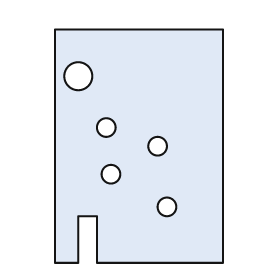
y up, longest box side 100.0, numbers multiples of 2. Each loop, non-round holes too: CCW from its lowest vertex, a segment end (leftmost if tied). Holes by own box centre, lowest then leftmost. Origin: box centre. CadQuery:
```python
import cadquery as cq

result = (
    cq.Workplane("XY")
    .moveTo(-36.0, -50.0)
    .lineTo(-26.0, -50.0)
    .lineTo(-26.0, -30.0)
    .lineTo(-18.0, -30.0)
    .lineTo(-18.0, -50.0)
    .lineTo(36.0, -50.0)
    .lineTo(36.0, 50.0)
    .lineTo(-36.0, 50.0)
    .close()
    .moveTo(12.0, -26.0)
    .circle(4.0)
    .moveTo(-12.0, -12.0)
    .circle(4.0)
    .moveTo(8.0, 0.0)
    .circle(4.0)
    .moveTo(-14.0, 8.0)
    .circle(4.0)
    .moveTo(-26.0, 30.0)
    .circle(6.0)
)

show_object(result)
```